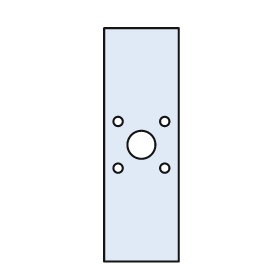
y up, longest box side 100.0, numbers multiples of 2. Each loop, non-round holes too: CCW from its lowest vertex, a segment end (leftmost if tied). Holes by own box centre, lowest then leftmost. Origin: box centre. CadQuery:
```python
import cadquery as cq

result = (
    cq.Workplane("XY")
    .moveTo(-16.0, -50.0)
    .lineTo(16.0, -50.0)
    .lineTo(16.0, 50.0)
    .lineTo(-16.0, 50.0)
    .close()
    .moveTo(-10.0, -10.0)
    .circle(2.0)
    .moveTo(10.0, -10.0)
    .circle(2.0)
    .moveTo(0.0, 0.0)
    .circle(6.0)
    .moveTo(-10.0, 10.0)
    .circle(2.0)
    .moveTo(10.0, 10.0)
    .circle(2.0)
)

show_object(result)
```